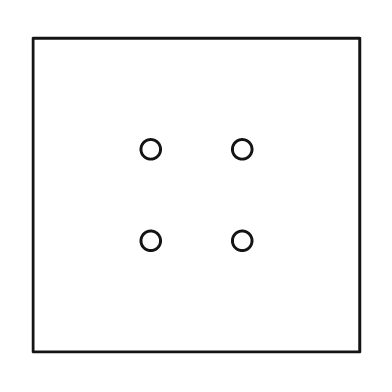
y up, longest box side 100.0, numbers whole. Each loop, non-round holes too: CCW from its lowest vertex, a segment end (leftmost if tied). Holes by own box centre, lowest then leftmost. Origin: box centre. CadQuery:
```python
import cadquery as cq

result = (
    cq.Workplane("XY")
    .moveTo(-50.0, -48.0)
    .lineTo(50.0, -48.0)
    .lineTo(50.0, 48.0)
    .lineTo(-50.0, 48.0)
    .close()
    .moveTo(-14.0, -14.0)
    .circle(3.0)
    .moveTo(14.0, -14.0)
    .circle(3.0)
    .moveTo(-14.0, 14.0)
    .circle(3.0)
    .moveTo(14.0, 14.0)
    .circle(3.0)
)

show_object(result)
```